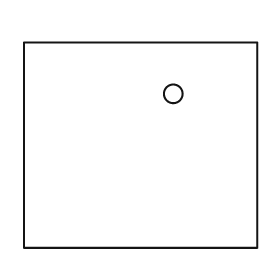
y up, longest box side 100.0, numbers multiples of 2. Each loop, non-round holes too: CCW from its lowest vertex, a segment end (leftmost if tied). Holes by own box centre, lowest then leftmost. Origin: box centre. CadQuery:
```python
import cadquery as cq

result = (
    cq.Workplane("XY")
    .moveTo(-50.0, -44.0)
    .lineTo(50.0, -44.0)
    .lineTo(50.0, 44.0)
    .lineTo(-50.0, 44.0)
    .close()
    .moveTo(14.0, 22.0)
    .circle(4.0)
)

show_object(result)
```